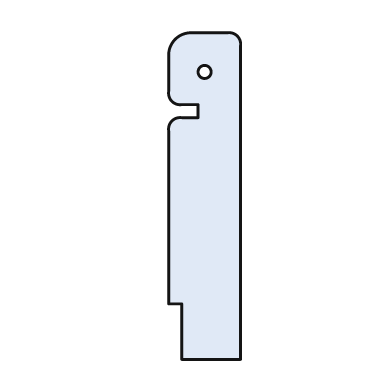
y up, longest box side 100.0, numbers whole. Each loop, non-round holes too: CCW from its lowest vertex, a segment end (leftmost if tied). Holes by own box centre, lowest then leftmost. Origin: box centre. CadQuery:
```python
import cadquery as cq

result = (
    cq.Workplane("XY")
    .moveTo(-7.0, -50.0)
    .lineTo(11.0, -50.0)
    .lineTo(11.0, 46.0)
    .threePointArc((10.0, 49.0), (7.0, 50.0))
    .lineTo(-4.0, 50.0)
    .threePointArc((-9.0, 48.0), (-11.0, 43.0))
    .lineTo(-11.0, 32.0)
    .threePointArc((-10.0, 29.0), (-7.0, 28.0))
    .lineTo(-2.0, 28.0)
    .lineTo(-2.0, 24.0)
    .lineTo(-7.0, 24.0)
    .threePointArc((-10.0, 23.0), (-11.0, 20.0))
    .lineTo(-11.0, -33.0)
    .lineTo(-7.0, -33.0)
    .close()
    .moveTo(0.0, 38.0)
    .circle(2.0)
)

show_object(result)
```